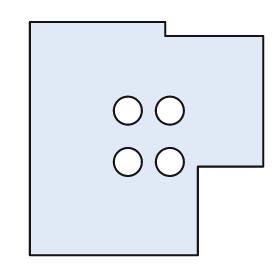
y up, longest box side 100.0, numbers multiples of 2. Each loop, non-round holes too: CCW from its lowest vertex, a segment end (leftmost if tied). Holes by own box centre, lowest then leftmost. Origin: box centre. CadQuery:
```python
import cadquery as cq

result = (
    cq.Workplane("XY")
    .moveTo(-50.0, -50.0)
    .lineTo(22.0, -50.0)
    .lineTo(22.0, -12.0)
    .lineTo(50.0, -12.0)
    .lineTo(50.0, 44.0)
    .lineTo(8.0, 44.0)
    .lineTo(8.0, 50.0)
    .lineTo(-50.0, 50.0)
    .close()
    .moveTo(-8.0, -10.0)
    .circle(6.0)
    .moveTo(10.0, -10.0)
    .circle(6.0)
    .moveTo(-8.0, 12.0)
    .circle(6.0)
    .moveTo(10.0, 12.0)
    .circle(6.0)
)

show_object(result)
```